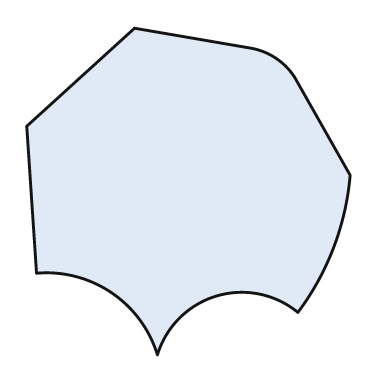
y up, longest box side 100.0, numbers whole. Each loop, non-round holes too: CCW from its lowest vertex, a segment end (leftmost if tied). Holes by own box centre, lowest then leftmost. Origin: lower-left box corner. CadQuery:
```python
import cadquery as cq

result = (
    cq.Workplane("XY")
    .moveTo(40.0, 0.0)
    .threePointArc((58.0, 18.0), (83.0, 13.0))
    .threePointArc((94.0, 33.0), (99.0, 55.0))
    .lineTo(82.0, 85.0)
    .threePointArc((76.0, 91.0), (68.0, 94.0))
    .lineTo(33.0, 100.0)
    .lineTo(0.0, 70.0)
    .lineTo(3.0, 25.0)
    .threePointArc((26.0, 19.0), (40.0, 0.0))
    .close()
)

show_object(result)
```